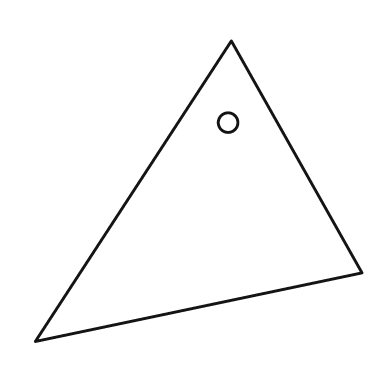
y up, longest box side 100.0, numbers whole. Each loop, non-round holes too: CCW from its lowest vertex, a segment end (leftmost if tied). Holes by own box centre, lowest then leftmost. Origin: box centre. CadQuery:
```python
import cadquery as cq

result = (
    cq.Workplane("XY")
    .moveTo(-50.0, -46.0)
    .lineTo(50.0, -25.0)
    .lineTo(10.0, 46.0)
    .close()
    .moveTo(9.0, 21.0)
    .circle(3.0)
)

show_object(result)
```